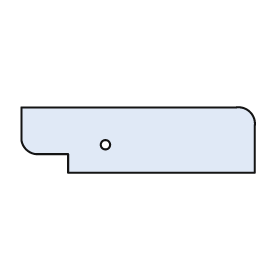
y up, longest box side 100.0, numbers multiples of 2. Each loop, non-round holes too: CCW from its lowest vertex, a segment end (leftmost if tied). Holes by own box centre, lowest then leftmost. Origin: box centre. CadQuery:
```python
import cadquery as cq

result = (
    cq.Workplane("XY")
    .moveTo(-30.0, -14.0)
    .lineTo(50.0, -14.0)
    .lineTo(50.0, 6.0)
    .threePointArc((48.0, 12.0), (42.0, 14.0))
    .lineTo(-50.0, 14.0)
    .lineTo(-50.0, 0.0)
    .threePointArc((-48.0, -4.0), (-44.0, -6.0))
    .lineTo(-30.0, -6.0)
    .close()
    .moveTo(-14.0, -2.0)
    .circle(2.0)
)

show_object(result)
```